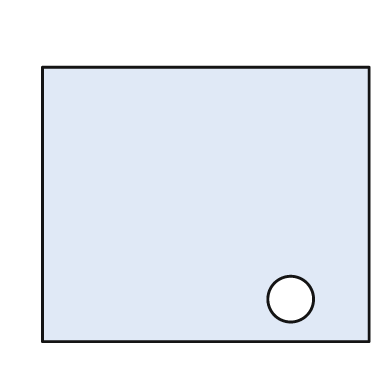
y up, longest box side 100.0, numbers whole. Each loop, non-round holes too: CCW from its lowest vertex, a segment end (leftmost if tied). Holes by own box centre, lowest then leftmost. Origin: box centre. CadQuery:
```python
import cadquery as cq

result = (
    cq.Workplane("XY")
    .moveTo(-50.0, -42.0)
    .lineTo(50.0, -42.0)
    .lineTo(50.0, 42.0)
    .lineTo(-50.0, 42.0)
    .close()
    .moveTo(26.0, -29.0)
    .circle(7.0)
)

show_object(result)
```